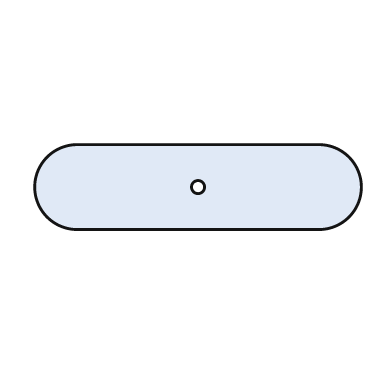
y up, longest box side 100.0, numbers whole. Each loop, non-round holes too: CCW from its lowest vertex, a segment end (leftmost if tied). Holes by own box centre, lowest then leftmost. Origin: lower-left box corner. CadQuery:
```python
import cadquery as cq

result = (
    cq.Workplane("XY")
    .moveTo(13.0, 0.0)
    .lineTo(87.0, 0.0)
    .threePointArc((100.0, 13.0), (87.0, 26.0))
    .lineTo(13.0, 26.0)
    .threePointArc((0.0, 13.0), (13.0, 0.0))
    .close()
    .moveTo(50.0, 13.0)
    .circle(2.0)
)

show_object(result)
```